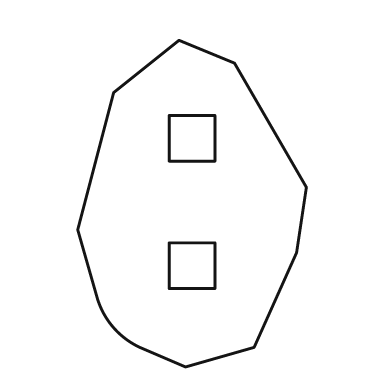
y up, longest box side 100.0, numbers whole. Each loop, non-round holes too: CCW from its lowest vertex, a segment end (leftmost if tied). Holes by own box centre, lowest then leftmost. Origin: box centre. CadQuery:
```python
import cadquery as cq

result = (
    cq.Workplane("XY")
    .moveTo(-2.0, -50.0)
    .lineTo(19.0, -44.0)
    .lineTo(32.0, -15.0)
    .lineTo(35.0, 5.0)
    .lineTo(13.0, 43.0)
    .lineTo(-4.0, 50.0)
    .lineTo(-24.0, 34.0)
    .lineTo(-35.0, -8.0)
    .lineTo(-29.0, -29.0)
    .threePointArc((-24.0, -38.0), (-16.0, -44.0))
    .close()
    .moveTo(-7.0, -26.0)
    .lineTo(7.0, -26.0)
    .lineTo(7.0, -12.0)
    .lineTo(-7.0, -12.0)
    .close()
    .moveTo(-7.0, 13.0)
    .lineTo(7.0, 13.0)
    .lineTo(7.0, 27.0)
    .lineTo(-7.0, 27.0)
    .close()
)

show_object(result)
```